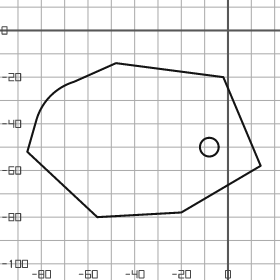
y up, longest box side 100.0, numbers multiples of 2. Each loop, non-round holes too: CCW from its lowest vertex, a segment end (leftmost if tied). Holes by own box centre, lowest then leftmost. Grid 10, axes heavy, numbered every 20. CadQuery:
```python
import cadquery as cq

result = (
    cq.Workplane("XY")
    .moveTo(-56.0, -80.0)
    .lineTo(-20.0, -78.0)
    .lineTo(14.0, -58.0)
    .lineTo(-2.0, -20.0)
    .lineTo(-48.0, -14.0)
    .lineTo(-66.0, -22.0)
    .threePointArc((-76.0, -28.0), (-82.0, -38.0))
    .lineTo(-86.0, -52.0)
    .close()
    .moveTo(-8.0, -50.0)
    .circle(4.0)
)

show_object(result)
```